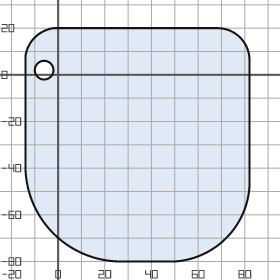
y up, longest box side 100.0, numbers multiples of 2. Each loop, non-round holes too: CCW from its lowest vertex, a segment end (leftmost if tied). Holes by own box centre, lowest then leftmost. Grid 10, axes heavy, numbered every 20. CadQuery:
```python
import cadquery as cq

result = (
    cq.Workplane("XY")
    .moveTo(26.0, -80.0)
    .lineTo(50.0, -80.0)
    .threePointArc((72.0, -70.0), (82.0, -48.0))
    .lineTo(82.0, 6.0)
    .threePointArc((78.0, 16.0), (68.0, 20.0))
    .lineTo(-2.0, 20.0)
    .threePointArc((-10.0, 16.0), (-14.0, 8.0))
    .lineTo(-14.0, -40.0)
    .threePointArc((-2.0, -68.0), (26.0, -80.0))
    .close()
    .moveTo(-6.0, 2.0)
    .circle(4.0)
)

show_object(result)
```